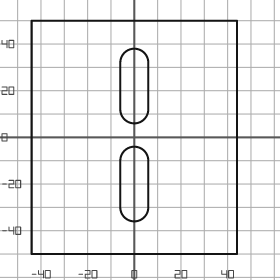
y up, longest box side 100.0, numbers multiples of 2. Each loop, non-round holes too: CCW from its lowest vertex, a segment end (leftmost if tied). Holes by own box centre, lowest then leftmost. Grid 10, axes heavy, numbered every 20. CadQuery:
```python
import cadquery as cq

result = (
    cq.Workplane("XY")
    .moveTo(-44.0, -50.0)
    .lineTo(44.0, -50.0)
    .lineTo(44.0, 50.0)
    .lineTo(-44.0, 50.0)
    .close()
    .moveTo(-6.0, -30.0)
    .threePointArc((0.0, -36.0), (6.0, -30.0))
    .lineTo(6.0, -10.0)
    .threePointArc((0.0, -4.0), (-6.0, -10.0))
    .close()
    .moveTo(-6.0, 12.0)
    .threePointArc((0.0, 6.0), (6.0, 12.0))
    .lineTo(6.0, 32.0)
    .threePointArc((0.0, 38.0), (-6.0, 32.0))
    .close()
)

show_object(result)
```